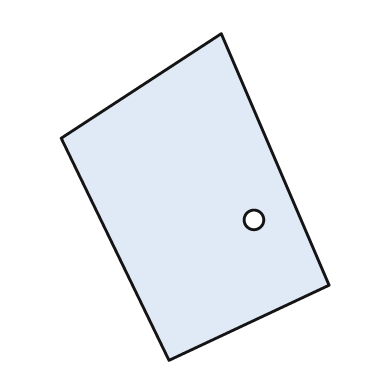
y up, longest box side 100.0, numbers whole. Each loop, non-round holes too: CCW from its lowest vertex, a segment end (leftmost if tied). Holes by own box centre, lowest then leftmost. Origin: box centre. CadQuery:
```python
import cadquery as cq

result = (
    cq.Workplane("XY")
    .moveTo(-8.0, -50.0)
    .lineTo(41.0, -27.0)
    .lineTo(8.0, 50.0)
    .lineTo(-41.0, 18.0)
    .close()
    .moveTo(18.0, -7.0)
    .circle(3.0)
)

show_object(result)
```